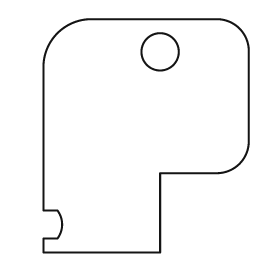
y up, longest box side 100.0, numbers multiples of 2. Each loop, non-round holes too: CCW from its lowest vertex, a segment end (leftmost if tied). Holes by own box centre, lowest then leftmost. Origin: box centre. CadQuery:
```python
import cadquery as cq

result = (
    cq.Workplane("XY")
    .moveTo(-44.0, -50.0)
    .lineTo(6.0, -50.0)
    .lineTo(6.0, -16.0)
    .lineTo(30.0, -16.0)
    .threePointArc((40.0, -12.0), (44.0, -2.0))
    .lineTo(44.0, 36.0)
    .threePointArc((40.0, 46.0), (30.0, 50.0))
    .lineTo(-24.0, 50.0)
    .threePointArc((-38.0, 44.0), (-44.0, 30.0))
    .lineTo(-44.0, -32.0)
    .lineTo(-38.0, -32.0)
    .threePointArc((-36.0, -38.0), (-38.0, -44.0))
    .lineTo(-44.0, -44.0)
    .close()
    .moveTo(6.0, 36.0)
    .circle(8.0)
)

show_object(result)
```